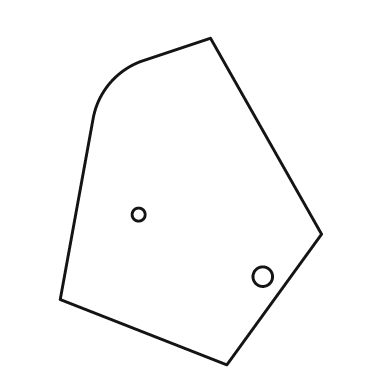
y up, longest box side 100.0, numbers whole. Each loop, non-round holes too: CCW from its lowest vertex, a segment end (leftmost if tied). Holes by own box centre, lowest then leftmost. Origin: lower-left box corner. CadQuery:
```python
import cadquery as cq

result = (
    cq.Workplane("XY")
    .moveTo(51.0, 0.0)
    .lineTo(80.0, 40.0)
    .lineTo(46.0, 100.0)
    .lineTo(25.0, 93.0)
    .threePointArc((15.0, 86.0), (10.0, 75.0))
    .lineTo(0.0, 20.0)
    .close()
    .moveTo(62.0, 27.0)
    .circle(3.0)
    .moveTo(24.0, 46.0)
    .circle(2.0)
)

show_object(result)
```